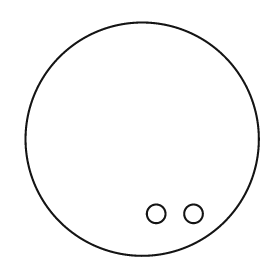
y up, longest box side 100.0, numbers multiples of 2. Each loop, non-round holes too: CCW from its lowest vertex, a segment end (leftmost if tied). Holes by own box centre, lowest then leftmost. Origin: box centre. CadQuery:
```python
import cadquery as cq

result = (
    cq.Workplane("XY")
    .moveTo(0.0, 0.0)
    .circle(50.0)
    .moveTo(6.0, -32.0)
    .circle(4.0)
    .moveTo(22.0, -32.0)
    .circle(4.0)
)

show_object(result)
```